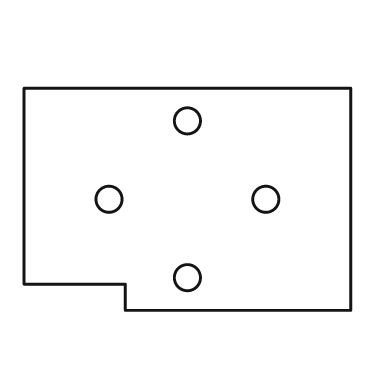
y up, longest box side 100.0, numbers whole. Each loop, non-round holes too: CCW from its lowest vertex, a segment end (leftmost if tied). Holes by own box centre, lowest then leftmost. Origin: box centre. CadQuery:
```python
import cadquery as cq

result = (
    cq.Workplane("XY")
    .moveTo(-19.0, -34.0)
    .lineTo(50.0, -34.0)
    .lineTo(50.0, 34.0)
    .lineTo(-50.0, 34.0)
    .lineTo(-50.0, -26.0)
    .lineTo(-19.0, -26.0)
    .close()
    .moveTo(0.0, -24.0)
    .circle(4.0)
    .moveTo(-24.0, 0.0)
    .circle(4.0)
    .moveTo(24.0, 0.0)
    .circle(4.0)
    .moveTo(0.0, 24.0)
    .circle(4.0)
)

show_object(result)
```